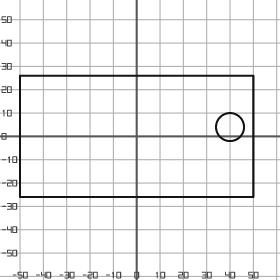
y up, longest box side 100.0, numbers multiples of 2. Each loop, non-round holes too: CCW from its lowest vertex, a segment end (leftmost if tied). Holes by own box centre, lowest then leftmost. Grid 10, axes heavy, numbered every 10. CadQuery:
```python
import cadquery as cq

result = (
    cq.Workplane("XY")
    .moveTo(-50.0, -26.0)
    .lineTo(50.0, -26.0)
    .lineTo(50.0, 26.0)
    .lineTo(-50.0, 26.0)
    .close()
    .moveTo(40.0, 4.0)
    .circle(6.0)
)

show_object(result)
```